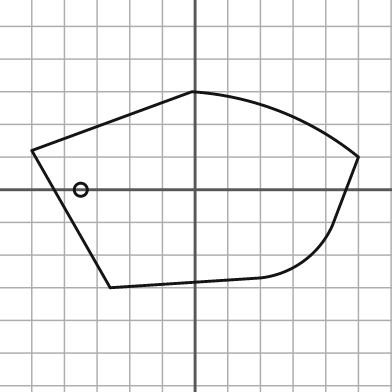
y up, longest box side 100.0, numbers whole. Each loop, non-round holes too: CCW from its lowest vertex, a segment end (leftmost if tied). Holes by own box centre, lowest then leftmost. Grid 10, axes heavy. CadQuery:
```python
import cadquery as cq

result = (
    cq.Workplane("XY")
    .moveTo(-26.0, -30.0)
    .lineTo(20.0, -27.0)
    .threePointArc((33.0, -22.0), (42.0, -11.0))
    .lineTo(50.0, 10.0)
    .threePointArc((26.0, 24.0), (-1.0, 30.0))
    .lineTo(-50.0, 12.0)
    .close()
    .moveTo(-35.0, 0.0)
    .circle(2.0)
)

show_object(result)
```